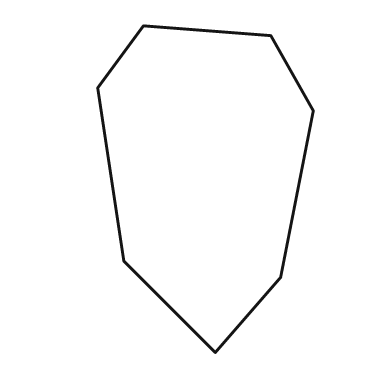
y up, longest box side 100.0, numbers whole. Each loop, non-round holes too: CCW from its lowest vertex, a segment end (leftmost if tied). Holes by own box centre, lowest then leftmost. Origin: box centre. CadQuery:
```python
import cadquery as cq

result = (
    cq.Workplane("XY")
    .moveTo(3.0, -50.0)
    .lineTo(23.0, -27.0)
    .lineTo(33.0, 24.0)
    .lineTo(20.0, 47.0)
    .lineTo(-19.0, 50.0)
    .lineTo(-33.0, 31.0)
    .lineTo(-25.0, -22.0)
    .close()
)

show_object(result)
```